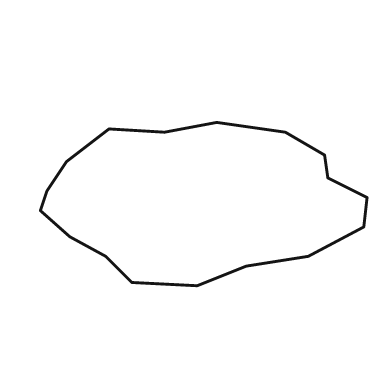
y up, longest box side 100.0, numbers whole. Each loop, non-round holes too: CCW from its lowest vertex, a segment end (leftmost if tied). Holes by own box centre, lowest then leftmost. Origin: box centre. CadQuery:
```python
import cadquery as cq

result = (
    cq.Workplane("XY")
    .moveTo(-2.0, -25.0)
    .lineTo(13.0, -19.0)
    .lineTo(32.0, -16.0)
    .lineTo(49.0, -7.0)
    .lineTo(50.0, 2.0)
    .lineTo(38.0, 8.0)
    .lineTo(37.0, 15.0)
    .lineTo(25.0, 22.0)
    .lineTo(4.0, 25.0)
    .lineTo(-12.0, 22.0)
    .lineTo(-29.0, 23.0)
    .lineTo(-42.0, 13.0)
    .lineTo(-48.0, 4.0)
    .lineTo(-50.0, -2.0)
    .lineTo(-41.0, -10.0)
    .lineTo(-30.0, -16.0)
    .lineTo(-22.0, -24.0)
    .close()
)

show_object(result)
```